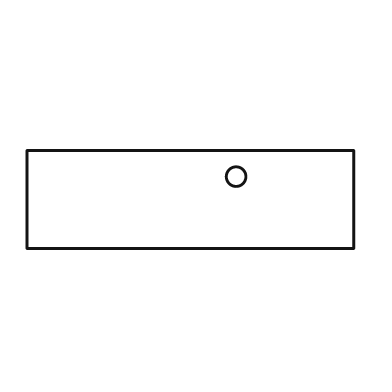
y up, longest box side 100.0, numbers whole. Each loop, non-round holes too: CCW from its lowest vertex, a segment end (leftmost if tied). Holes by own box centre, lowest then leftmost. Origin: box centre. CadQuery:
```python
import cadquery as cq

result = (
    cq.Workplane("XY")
    .moveTo(-50.0, -15.0)
    .lineTo(50.0, -15.0)
    .lineTo(50.0, 15.0)
    .lineTo(-50.0, 15.0)
    .close()
    .moveTo(14.0, 7.0)
    .circle(3.0)
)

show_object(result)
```